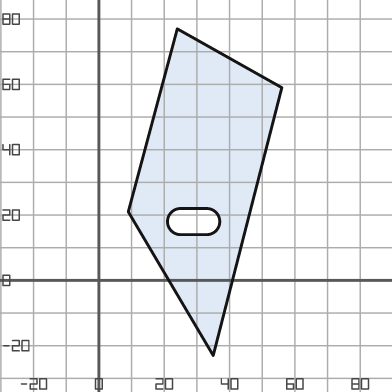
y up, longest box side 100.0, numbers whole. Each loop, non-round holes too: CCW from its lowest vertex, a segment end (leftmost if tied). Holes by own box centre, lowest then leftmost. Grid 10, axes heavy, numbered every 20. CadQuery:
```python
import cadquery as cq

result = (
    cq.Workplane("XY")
    .moveTo(35.0, -23.0)
    .lineTo(56.0, 59.0)
    .lineTo(24.0, 77.0)
    .lineTo(9.0, 21.0)
    .close()
    .moveTo(25.0, 14.0)
    .lineTo(33.0, 14.0)
    .threePointArc((37.0, 18.0), (33.0, 22.0))
    .lineTo(25.0, 22.0)
    .threePointArc((21.0, 18.0), (25.0, 14.0))
    .close()
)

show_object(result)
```